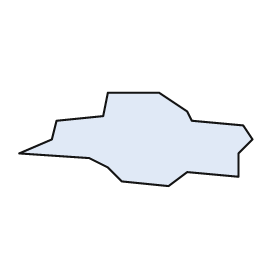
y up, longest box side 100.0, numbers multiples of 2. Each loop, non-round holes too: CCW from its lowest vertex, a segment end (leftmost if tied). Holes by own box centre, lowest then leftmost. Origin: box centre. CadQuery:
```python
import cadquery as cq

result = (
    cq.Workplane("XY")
    .moveTo(14.0, -20.0)
    .lineTo(22.0, -14.0)
    .lineTo(44.0, -16.0)
    .lineTo(44.0, -6.0)
    .lineTo(50.0, 0.0)
    .lineTo(46.0, 6.0)
    .lineTo(24.0, 8.0)
    .lineTo(22.0, 12.0)
    .lineTo(10.0, 20.0)
    .lineTo(-12.0, 20.0)
    .lineTo(-14.0, 10.0)
    .lineTo(-34.0, 8.0)
    .lineTo(-36.0, 0.0)
    .lineTo(-50.0, -6.0)
    .lineTo(-20.0, -8.0)
    .lineTo(-12.0, -12.0)
    .lineTo(-6.0, -18.0)
    .close()
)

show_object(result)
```